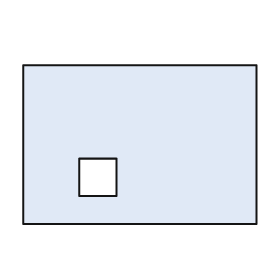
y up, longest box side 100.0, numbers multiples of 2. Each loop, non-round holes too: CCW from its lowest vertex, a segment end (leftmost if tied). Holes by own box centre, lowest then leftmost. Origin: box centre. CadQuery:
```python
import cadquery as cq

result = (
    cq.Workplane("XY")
    .moveTo(-50.0, -34.0)
    .lineTo(50.0, -34.0)
    .lineTo(50.0, 34.0)
    .lineTo(-50.0, 34.0)
    .close()
    .moveTo(-26.0, -22.0)
    .lineTo(-10.0, -22.0)
    .lineTo(-10.0, -6.0)
    .lineTo(-26.0, -6.0)
    .close()
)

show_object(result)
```